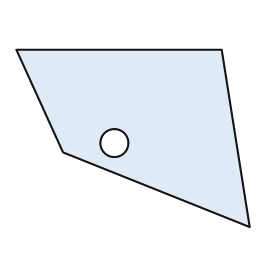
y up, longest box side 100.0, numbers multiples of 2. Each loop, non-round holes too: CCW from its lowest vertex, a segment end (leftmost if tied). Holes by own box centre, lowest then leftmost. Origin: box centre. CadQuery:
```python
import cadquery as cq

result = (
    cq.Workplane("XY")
    .moveTo(50.0, -38.0)
    .lineTo(38.0, 38.0)
    .lineTo(-50.0, 38.0)
    .lineTo(-30.0, -6.0)
    .close()
    .moveTo(-8.0, -2.0)
    .circle(6.0)
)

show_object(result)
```